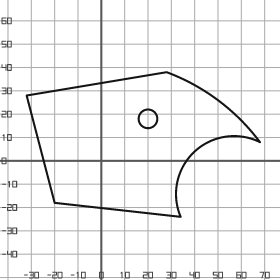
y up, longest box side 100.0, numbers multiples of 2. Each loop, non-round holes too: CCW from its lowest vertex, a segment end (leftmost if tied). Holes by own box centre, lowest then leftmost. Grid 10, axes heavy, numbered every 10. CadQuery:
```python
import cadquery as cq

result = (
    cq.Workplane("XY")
    .moveTo(34.0, -24.0)
    .threePointArc((40.0, 4.0), (68.0, 8.0))
    .threePointArc((50.0, 26.0), (28.0, 38.0))
    .lineTo(-32.0, 28.0)
    .lineTo(-20.0, -18.0)
    .close()
    .moveTo(20.0, 18.0)
    .circle(4.0)
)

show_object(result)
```